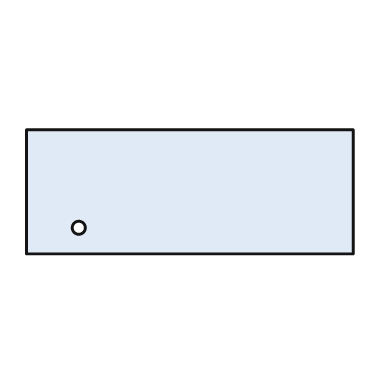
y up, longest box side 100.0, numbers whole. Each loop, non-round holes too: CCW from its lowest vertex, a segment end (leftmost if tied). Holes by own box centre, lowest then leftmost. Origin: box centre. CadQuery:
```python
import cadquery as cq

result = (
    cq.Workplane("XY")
    .moveTo(-50.0, -19.0)
    .lineTo(50.0, -19.0)
    .lineTo(50.0, 19.0)
    .lineTo(-50.0, 19.0)
    .close()
    .moveTo(-34.0, -11.0)
    .circle(2.0)
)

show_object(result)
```